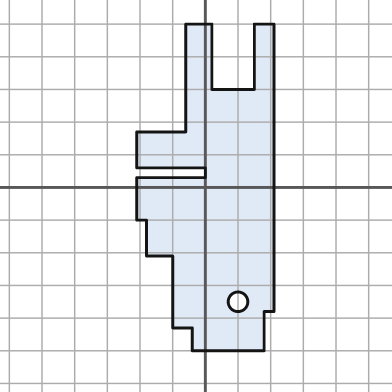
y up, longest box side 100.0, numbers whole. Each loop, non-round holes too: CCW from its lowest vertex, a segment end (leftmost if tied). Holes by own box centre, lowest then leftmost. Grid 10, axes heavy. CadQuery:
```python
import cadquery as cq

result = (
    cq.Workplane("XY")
    .moveTo(-4.0, -50.0)
    .lineTo(18.0, -50.0)
    .lineTo(18.0, -38.0)
    .lineTo(21.0, -38.0)
    .lineTo(21.0, 50.0)
    .lineTo(15.0, 50.0)
    .lineTo(15.0, 30.0)
    .lineTo(2.0, 30.0)
    .lineTo(2.0, 50.0)
    .lineTo(-6.0, 50.0)
    .lineTo(-6.0, 17.0)
    .lineTo(-21.0, 17.0)
    .lineTo(-21.0, 6.0)
    .lineTo(0.0, 6.0)
    .lineTo(0.0, 3.0)
    .lineTo(-21.0, 3.0)
    .lineTo(-21.0, -10.0)
    .lineTo(-18.0, -10.0)
    .lineTo(-18.0, -21.0)
    .lineTo(-10.0, -21.0)
    .lineTo(-10.0, -43.0)
    .lineTo(-4.0, -43.0)
    .close()
    .moveTo(10.0, -35.0)
    .circle(3.0)
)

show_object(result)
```